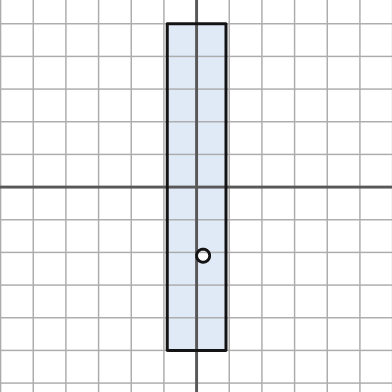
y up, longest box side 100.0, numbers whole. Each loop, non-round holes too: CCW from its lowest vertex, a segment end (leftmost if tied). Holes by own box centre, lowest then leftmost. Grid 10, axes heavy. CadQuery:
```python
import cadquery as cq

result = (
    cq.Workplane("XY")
    .moveTo(-9.0, -50.0)
    .lineTo(9.0, -50.0)
    .lineTo(9.0, 50.0)
    .lineTo(-9.0, 50.0)
    .close()
    .moveTo(2.0, -21.0)
    .circle(2.0)
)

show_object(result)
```